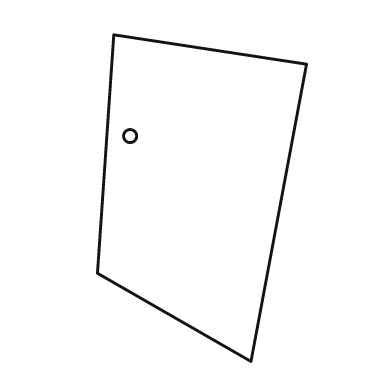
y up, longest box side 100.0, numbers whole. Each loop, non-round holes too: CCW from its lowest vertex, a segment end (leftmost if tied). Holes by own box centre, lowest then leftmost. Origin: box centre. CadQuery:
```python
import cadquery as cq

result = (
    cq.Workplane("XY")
    .moveTo(15.0, -50.0)
    .lineTo(32.0, 41.0)
    .lineTo(-27.0, 50.0)
    .lineTo(-32.0, -23.0)
    .close()
    .moveTo(-22.0, 19.0)
    .circle(2.0)
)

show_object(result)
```